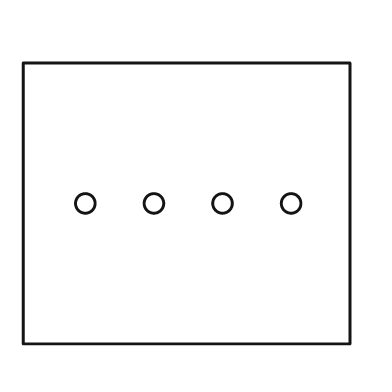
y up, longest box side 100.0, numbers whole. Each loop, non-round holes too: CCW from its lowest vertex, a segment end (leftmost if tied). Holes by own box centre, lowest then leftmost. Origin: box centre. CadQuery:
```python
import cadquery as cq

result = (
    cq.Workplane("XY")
    .moveTo(-50.0, -43.0)
    .lineTo(50.0, -43.0)
    .lineTo(50.0, 43.0)
    .lineTo(-50.0, 43.0)
    .close()
    .moveTo(-31.0, 0.0)
    .circle(3.0)
    .moveTo(-10.0, 0.0)
    .circle(3.0)
    .moveTo(11.0, 0.0)
    .circle(3.0)
    .moveTo(32.0, 0.0)
    .circle(3.0)
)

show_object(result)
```